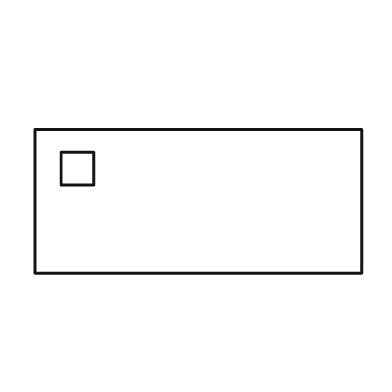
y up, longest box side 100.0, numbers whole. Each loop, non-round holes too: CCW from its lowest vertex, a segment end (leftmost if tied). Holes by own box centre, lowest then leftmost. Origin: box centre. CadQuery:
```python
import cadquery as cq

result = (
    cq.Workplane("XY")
    .moveTo(-50.0, -22.0)
    .lineTo(50.0, -22.0)
    .lineTo(50.0, 22.0)
    .lineTo(-50.0, 22.0)
    .close()
    .moveTo(-42.0, 5.0)
    .lineTo(-32.0, 5.0)
    .lineTo(-32.0, 15.0)
    .lineTo(-42.0, 15.0)
    .close()
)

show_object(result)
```